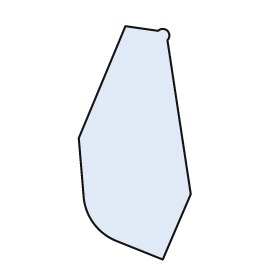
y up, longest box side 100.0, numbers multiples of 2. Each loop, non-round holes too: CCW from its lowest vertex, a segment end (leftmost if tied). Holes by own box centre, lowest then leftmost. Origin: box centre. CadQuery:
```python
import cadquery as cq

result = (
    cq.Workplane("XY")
    .moveTo(12.0, -50.0)
    .lineTo(24.0, -22.0)
    .lineTo(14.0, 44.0)
    .threePointArc((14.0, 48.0), (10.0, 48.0))
    .lineTo(-4.0, 50.0)
    .lineTo(-24.0, 2.0)
    .lineTo(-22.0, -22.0)
    .threePointArc((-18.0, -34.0), (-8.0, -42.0))
    .close()
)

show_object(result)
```